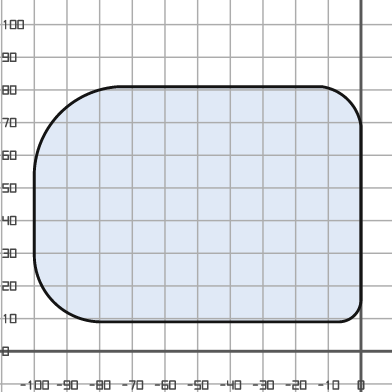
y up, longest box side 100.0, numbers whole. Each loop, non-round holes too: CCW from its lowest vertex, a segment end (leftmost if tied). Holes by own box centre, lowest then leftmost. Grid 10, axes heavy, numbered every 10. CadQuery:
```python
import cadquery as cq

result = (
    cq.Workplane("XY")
    .moveTo(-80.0, 9.0)
    .lineTo(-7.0, 9.0)
    .threePointArc((-2.0, 11.0), (0.0, 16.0))
    .lineTo(0.0, 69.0)
    .threePointArc((-4.0, 77.0), (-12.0, 81.0))
    .lineTo(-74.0, 81.0)
    .threePointArc((-92.0, 73.0), (-100.0, 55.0))
    .lineTo(-100.0, 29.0)
    .threePointArc((-94.0, 15.0), (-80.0, 9.0))
    .close()
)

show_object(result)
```